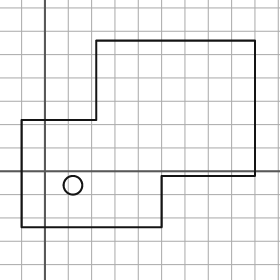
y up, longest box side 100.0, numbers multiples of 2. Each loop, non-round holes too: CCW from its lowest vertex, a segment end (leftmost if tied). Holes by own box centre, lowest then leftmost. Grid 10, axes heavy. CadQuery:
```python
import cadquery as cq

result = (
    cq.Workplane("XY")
    .moveTo(-10.0, -24.0)
    .lineTo(50.0, -24.0)
    .lineTo(50.0, -2.0)
    .lineTo(90.0, -2.0)
    .lineTo(90.0, 56.0)
    .lineTo(22.0, 56.0)
    .lineTo(22.0, 22.0)
    .lineTo(-10.0, 22.0)
    .close()
    .moveTo(12.0, -6.0)
    .circle(4.0)
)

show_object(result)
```